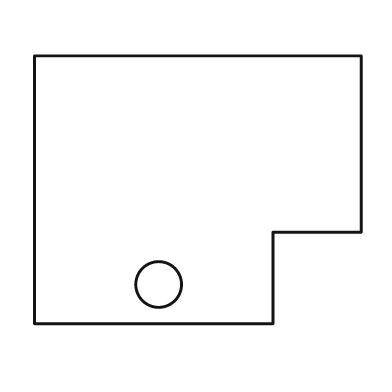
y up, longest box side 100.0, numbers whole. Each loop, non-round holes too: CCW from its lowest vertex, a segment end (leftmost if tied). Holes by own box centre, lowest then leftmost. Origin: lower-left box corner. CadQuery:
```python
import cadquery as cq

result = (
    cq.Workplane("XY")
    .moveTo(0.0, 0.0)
    .lineTo(73.0, 0.0)
    .lineTo(73.0, 28.0)
    .lineTo(100.0, 28.0)
    .lineTo(100.0, 82.0)
    .lineTo(0.0, 82.0)
    .close()
    .moveTo(38.0, 12.0)
    .circle(7.0)
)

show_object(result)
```